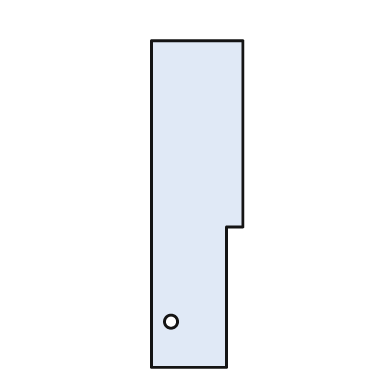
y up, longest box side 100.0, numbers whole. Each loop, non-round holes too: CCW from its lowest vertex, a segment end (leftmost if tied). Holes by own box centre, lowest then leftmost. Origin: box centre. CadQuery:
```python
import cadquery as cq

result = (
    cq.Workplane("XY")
    .moveTo(-14.0, -50.0)
    .lineTo(9.0, -50.0)
    .lineTo(9.0, -7.0)
    .lineTo(14.0, -7.0)
    .lineTo(14.0, 50.0)
    .lineTo(-14.0, 50.0)
    .close()
    .moveTo(-8.0, -36.0)
    .circle(2.0)
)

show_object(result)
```